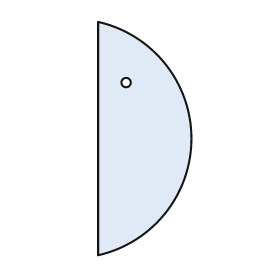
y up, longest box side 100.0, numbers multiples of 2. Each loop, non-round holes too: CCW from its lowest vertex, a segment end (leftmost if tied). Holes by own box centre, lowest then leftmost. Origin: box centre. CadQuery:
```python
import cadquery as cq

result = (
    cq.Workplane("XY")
    .moveTo(-20.0, -50.0)
    .threePointArc((20.0, 0.0), (-20.0, 50.0))
    .close()
    .moveTo(-8.0, 24.0)
    .circle(2.0)
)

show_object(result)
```